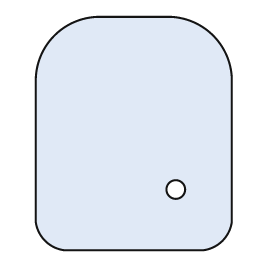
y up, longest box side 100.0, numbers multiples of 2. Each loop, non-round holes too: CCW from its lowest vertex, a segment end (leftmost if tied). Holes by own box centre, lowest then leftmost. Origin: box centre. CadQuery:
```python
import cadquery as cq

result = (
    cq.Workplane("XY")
    .moveTo(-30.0, -50.0)
    .lineTo(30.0, -50.0)
    .threePointArc((38.0, -46.0), (42.0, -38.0))
    .lineTo(42.0, 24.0)
    .threePointArc((34.0, 42.0), (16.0, 50.0))
    .lineTo(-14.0, 50.0)
    .threePointArc((-34.0, 42.0), (-42.0, 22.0))
    .lineTo(-42.0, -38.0)
    .threePointArc((-38.0, -46.0), (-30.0, -50.0))
    .close()
    .moveTo(18.0, -24.0)
    .circle(4.0)
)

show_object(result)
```